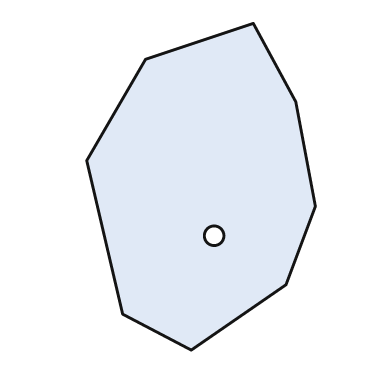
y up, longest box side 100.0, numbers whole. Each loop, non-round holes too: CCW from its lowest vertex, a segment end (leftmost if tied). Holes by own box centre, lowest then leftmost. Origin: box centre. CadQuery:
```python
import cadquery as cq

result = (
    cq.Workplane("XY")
    .moveTo(-3.0, -50.0)
    .lineTo(26.0, -30.0)
    .lineTo(35.0, -6.0)
    .lineTo(29.0, 26.0)
    .lineTo(16.0, 50.0)
    .lineTo(-17.0, 39.0)
    .lineTo(-35.0, 8.0)
    .lineTo(-24.0, -39.0)
    .close()
    .moveTo(4.0, -15.0)
    .circle(3.0)
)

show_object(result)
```